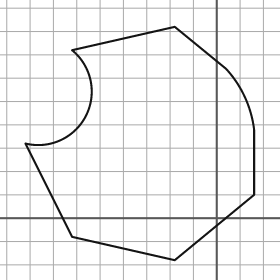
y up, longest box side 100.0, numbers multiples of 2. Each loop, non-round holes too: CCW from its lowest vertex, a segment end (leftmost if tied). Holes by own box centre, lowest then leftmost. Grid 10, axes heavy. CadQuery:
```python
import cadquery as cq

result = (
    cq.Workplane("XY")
    .moveTo(-18.0, -18.0)
    .lineTo(16.0, 10.0)
    .lineTo(16.0, 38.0)
    .threePointArc((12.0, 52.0), (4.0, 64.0))
    .lineTo(-18.0, 82.0)
    .lineTo(-62.0, 72.0)
    .threePointArc((-56.0, 44.0), (-82.0, 32.0))
    .lineTo(-62.0, -8.0)
    .close()
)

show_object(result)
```